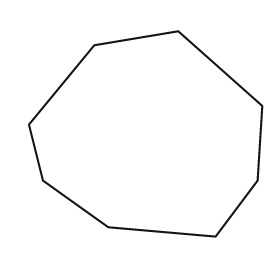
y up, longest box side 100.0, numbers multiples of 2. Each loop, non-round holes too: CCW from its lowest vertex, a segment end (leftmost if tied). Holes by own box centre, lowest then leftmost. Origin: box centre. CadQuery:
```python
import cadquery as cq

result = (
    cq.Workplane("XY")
    .moveTo(30.0, -44.0)
    .lineTo(48.0, -20.0)
    .lineTo(50.0, 12.0)
    .lineTo(14.0, 44.0)
    .lineTo(-22.0, 38.0)
    .lineTo(-50.0, 4.0)
    .lineTo(-44.0, -20.0)
    .lineTo(-16.0, -40.0)
    .close()
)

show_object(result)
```